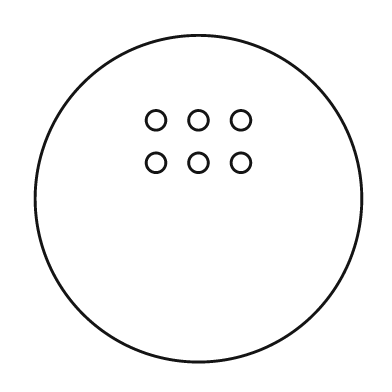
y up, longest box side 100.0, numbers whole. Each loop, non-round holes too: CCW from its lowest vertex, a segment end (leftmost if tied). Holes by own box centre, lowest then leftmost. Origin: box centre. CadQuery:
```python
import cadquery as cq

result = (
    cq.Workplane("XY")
    .moveTo(0.0, 0.0)
    .circle(50.0)
    .moveTo(-13.0, 11.0)
    .circle(3.0)
    .moveTo(0.0, 11.0)
    .circle(3.0)
    .moveTo(13.0, 11.0)
    .circle(3.0)
    .moveTo(-13.0, 24.0)
    .circle(3.0)
    .moveTo(0.0, 24.0)
    .circle(3.0)
    .moveTo(13.0, 24.0)
    .circle(3.0)
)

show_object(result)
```